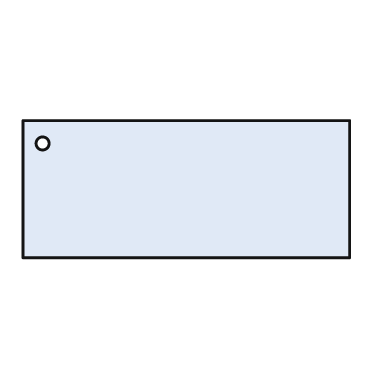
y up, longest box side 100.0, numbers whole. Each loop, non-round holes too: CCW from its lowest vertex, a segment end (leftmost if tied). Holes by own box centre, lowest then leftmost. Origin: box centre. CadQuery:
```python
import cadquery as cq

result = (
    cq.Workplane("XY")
    .moveTo(-50.0, -21.0)
    .lineTo(50.0, -21.0)
    .lineTo(50.0, 21.0)
    .lineTo(-50.0, 21.0)
    .close()
    .moveTo(-44.0, 14.0)
    .circle(2.0)
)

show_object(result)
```